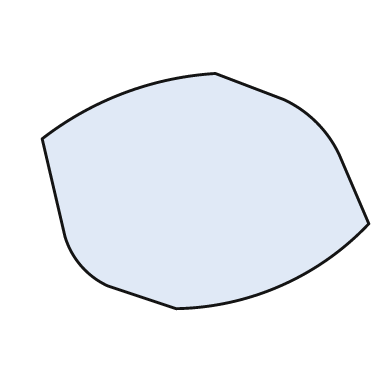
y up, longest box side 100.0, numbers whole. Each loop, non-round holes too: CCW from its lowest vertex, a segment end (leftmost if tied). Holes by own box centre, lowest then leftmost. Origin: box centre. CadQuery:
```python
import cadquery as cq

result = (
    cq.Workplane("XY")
    .moveTo(-9.0, -36.0)
    .threePointArc((23.0, -29.0), (50.0, -10.0))
    .lineTo(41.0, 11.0)
    .threePointArc((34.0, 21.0), (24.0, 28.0))
    .lineTo(3.0, 36.0)
    .threePointArc((-25.0, 30.0), (-50.0, 16.0))
    .lineTo(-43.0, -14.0)
    .threePointArc((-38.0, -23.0), (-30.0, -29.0))
    .close()
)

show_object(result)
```